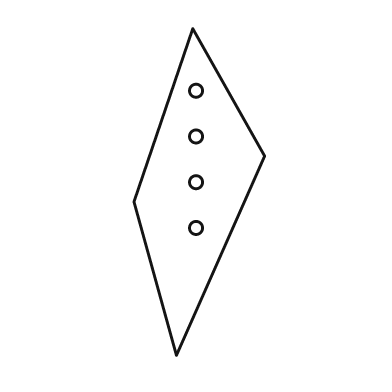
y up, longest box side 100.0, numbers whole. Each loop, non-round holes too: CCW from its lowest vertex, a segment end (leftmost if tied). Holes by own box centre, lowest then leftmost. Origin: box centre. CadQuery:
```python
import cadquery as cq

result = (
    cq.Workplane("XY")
    .moveTo(-7.0, -50.0)
    .lineTo(20.0, 11.0)
    .lineTo(-2.0, 50.0)
    .lineTo(-20.0, -3.0)
    .close()
    .moveTo(-1.0, -11.0)
    .circle(2.0)
    .moveTo(-1.0, 3.0)
    .circle(2.0)
    .moveTo(-1.0, 17.0)
    .circle(2.0)
    .moveTo(-1.0, 31.0)
    .circle(2.0)
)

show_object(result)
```